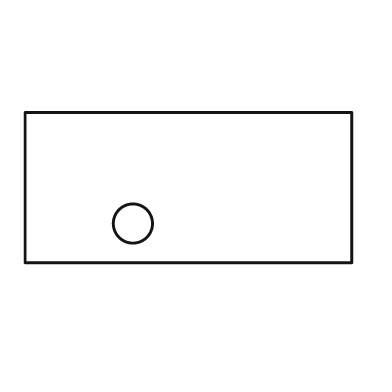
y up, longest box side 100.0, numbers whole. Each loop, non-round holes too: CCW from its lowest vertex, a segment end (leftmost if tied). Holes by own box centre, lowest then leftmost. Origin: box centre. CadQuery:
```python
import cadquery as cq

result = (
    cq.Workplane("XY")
    .moveTo(-50.0, -23.0)
    .lineTo(50.0, -23.0)
    .lineTo(50.0, 23.0)
    .lineTo(-50.0, 23.0)
    .close()
    .moveTo(-17.0, -11.0)
    .circle(6.0)
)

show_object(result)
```